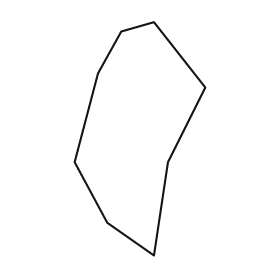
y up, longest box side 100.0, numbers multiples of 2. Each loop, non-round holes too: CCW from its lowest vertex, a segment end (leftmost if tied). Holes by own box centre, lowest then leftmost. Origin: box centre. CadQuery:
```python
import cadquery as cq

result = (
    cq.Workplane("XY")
    .moveTo(6.0, -50.0)
    .lineTo(12.0, -10.0)
    .lineTo(28.0, 22.0)
    .lineTo(6.0, 50.0)
    .lineTo(-8.0, 46.0)
    .lineTo(-18.0, 28.0)
    .lineTo(-28.0, -10.0)
    .lineTo(-14.0, -36.0)
    .close()
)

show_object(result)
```